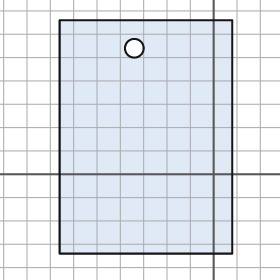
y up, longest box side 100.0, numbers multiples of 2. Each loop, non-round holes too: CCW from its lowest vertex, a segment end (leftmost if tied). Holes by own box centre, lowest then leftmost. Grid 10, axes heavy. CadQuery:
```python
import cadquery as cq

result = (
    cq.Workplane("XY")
    .moveTo(-66.0, -34.0)
    .lineTo(8.0, -34.0)
    .lineTo(8.0, 66.0)
    .lineTo(-66.0, 66.0)
    .close()
    .moveTo(-34.0, 54.0)
    .circle(4.0)
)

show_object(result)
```